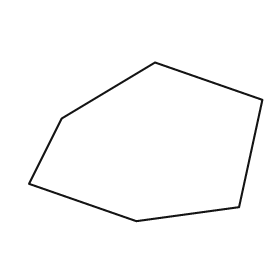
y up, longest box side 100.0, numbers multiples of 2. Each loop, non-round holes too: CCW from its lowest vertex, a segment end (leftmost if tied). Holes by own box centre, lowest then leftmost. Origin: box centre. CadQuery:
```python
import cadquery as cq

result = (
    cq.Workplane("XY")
    .moveTo(-4.0, -34.0)
    .lineTo(40.0, -28.0)
    .lineTo(50.0, 18.0)
    .lineTo(4.0, 34.0)
    .lineTo(-36.0, 10.0)
    .lineTo(-50.0, -18.0)
    .close()
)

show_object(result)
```